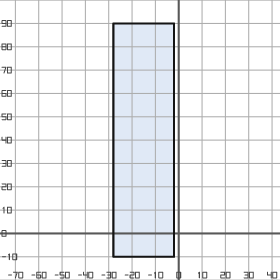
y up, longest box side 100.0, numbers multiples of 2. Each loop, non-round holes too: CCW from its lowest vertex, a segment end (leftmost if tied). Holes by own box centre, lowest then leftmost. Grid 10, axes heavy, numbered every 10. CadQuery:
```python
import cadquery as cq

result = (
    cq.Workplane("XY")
    .moveTo(-28.0, -10.0)
    .lineTo(-2.0, -10.0)
    .lineTo(-2.0, 90.0)
    .lineTo(-28.0, 90.0)
    .close()
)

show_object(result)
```